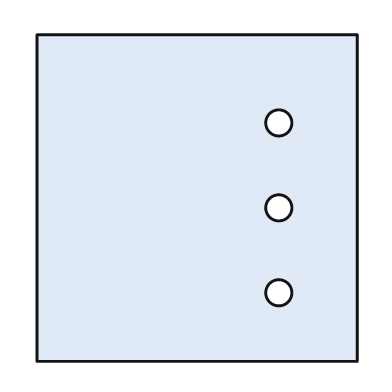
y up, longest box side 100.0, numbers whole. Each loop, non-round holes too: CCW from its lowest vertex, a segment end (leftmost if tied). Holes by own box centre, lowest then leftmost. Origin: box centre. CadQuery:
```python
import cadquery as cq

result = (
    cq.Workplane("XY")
    .moveTo(-49.0, -50.0)
    .lineTo(49.0, -50.0)
    .lineTo(49.0, 50.0)
    .lineTo(-49.0, 50.0)
    .close()
    .moveTo(25.0, -29.0)
    .circle(4.0)
    .moveTo(25.0, -3.0)
    .circle(4.0)
    .moveTo(25.0, 23.0)
    .circle(4.0)
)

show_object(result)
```